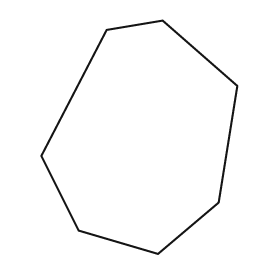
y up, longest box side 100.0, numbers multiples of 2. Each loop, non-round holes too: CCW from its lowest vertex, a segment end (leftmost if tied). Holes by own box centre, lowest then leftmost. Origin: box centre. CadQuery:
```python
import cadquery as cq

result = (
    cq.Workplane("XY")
    .moveTo(8.0, -50.0)
    .lineTo(34.0, -28.0)
    .lineTo(42.0, 22.0)
    .lineTo(10.0, 50.0)
    .lineTo(-14.0, 46.0)
    .lineTo(-42.0, -8.0)
    .lineTo(-26.0, -40.0)
    .close()
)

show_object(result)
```